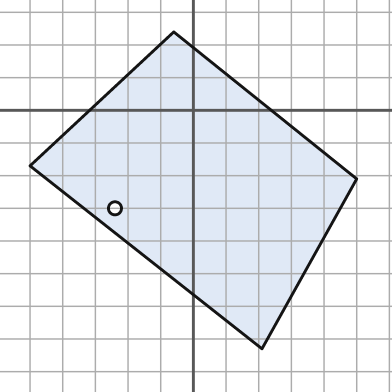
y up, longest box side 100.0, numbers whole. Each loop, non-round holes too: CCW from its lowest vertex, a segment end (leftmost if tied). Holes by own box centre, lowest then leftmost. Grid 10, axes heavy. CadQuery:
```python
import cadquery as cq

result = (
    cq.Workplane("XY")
    .moveTo(21.0, -73.0)
    .lineTo(50.0, -21.0)
    .lineTo(-6.0, 24.0)
    .lineTo(-50.0, -17.0)
    .close()
    .moveTo(-24.0, -30.0)
    .circle(2.0)
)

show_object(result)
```